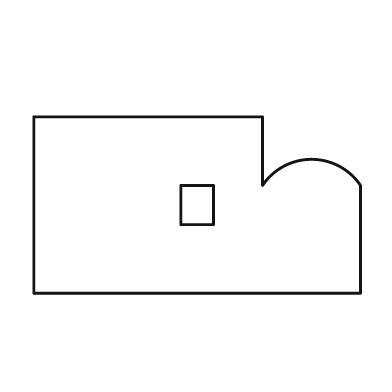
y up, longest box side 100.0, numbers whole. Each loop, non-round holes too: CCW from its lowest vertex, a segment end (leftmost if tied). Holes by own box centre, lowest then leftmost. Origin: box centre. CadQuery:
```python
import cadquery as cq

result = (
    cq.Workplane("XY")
    .moveTo(-50.0, -27.0)
    .lineTo(50.0, -27.0)
    .lineTo(50.0, 6.0)
    .threePointArc((35.0, 14.0), (20.0, 6.0))
    .lineTo(20.0, 27.0)
    .lineTo(-50.0, 27.0)
    .close()
    .moveTo(-5.0, -6.0)
    .lineTo(5.0, -6.0)
    .lineTo(5.0, 6.0)
    .lineTo(-5.0, 6.0)
    .close()
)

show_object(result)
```